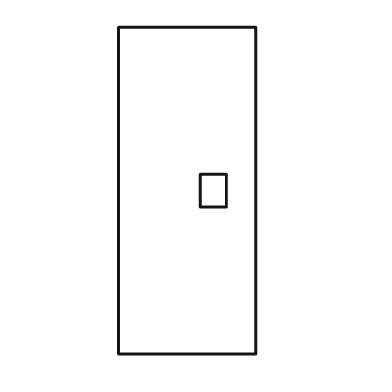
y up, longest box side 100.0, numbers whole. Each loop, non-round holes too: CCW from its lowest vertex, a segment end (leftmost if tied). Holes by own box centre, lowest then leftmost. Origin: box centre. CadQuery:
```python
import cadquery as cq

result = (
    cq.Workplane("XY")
    .moveTo(-21.0, -50.0)
    .lineTo(21.0, -50.0)
    .lineTo(21.0, 50.0)
    .lineTo(-21.0, 50.0)
    .close()
    .moveTo(4.0, -5.0)
    .lineTo(12.0, -5.0)
    .lineTo(12.0, 5.0)
    .lineTo(4.0, 5.0)
    .close()
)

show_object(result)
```